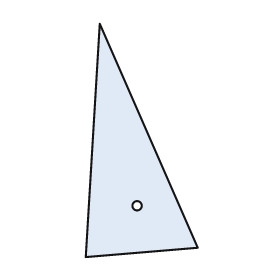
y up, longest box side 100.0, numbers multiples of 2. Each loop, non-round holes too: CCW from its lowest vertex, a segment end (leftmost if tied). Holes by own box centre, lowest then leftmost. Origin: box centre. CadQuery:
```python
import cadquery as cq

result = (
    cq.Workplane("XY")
    .moveTo(-24.0, -50.0)
    .lineTo(24.0, -46.0)
    .lineTo(-18.0, 50.0)
    .close()
    .moveTo(-2.0, -28.0)
    .circle(2.0)
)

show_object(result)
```